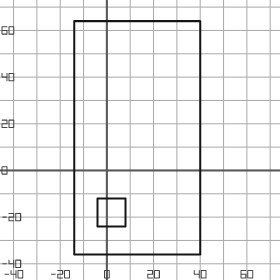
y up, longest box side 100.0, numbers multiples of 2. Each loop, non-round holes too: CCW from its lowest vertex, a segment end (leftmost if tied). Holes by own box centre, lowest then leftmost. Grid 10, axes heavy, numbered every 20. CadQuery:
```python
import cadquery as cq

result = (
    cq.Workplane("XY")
    .moveTo(-14.0, -36.0)
    .lineTo(40.0, -36.0)
    .lineTo(40.0, 64.0)
    .lineTo(-14.0, 64.0)
    .close()
    .moveTo(-4.0, -24.0)
    .lineTo(8.0, -24.0)
    .lineTo(8.0, -12.0)
    .lineTo(-4.0, -12.0)
    .close()
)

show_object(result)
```